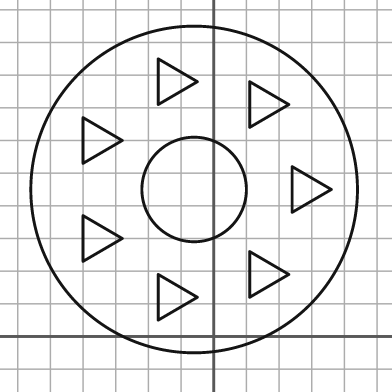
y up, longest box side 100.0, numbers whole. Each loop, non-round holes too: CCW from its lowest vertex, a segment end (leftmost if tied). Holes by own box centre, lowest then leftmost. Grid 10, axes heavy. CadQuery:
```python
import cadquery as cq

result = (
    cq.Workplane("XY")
    .moveTo(-6.0, 45.0)
    .circle(50.0)
    .moveTo(-17.0, 5.0)
    .lineTo(-5.0, 12.0)
    .lineTo(-17.0, 19.0)
    .close()
    .moveTo(11.0, 12.0)
    .lineTo(23.0, 19.0)
    .lineTo(11.0, 26.0)
    .close()
    .moveTo(-40.0, 23.0)
    .lineTo(-28.0, 30.0)
    .lineTo(-40.0, 37.0)
    .close()
    .moveTo(-6.0, 45.0)
    .circle(16.0)
    .moveTo(24.0, 38.0)
    .lineTo(36.0, 45.0)
    .lineTo(24.0, 52.0)
    .close()
    .moveTo(-40.0, 53.0)
    .lineTo(-28.0, 60.0)
    .lineTo(-40.0, 67.0)
    .close()
    .moveTo(11.0, 64.0)
    .lineTo(23.0, 71.0)
    .lineTo(11.0, 78.0)
    .close()
    .moveTo(-17.0, 71.0)
    .lineTo(-5.0, 78.0)
    .lineTo(-17.0, 85.0)
    .close()
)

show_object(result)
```